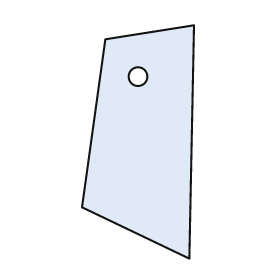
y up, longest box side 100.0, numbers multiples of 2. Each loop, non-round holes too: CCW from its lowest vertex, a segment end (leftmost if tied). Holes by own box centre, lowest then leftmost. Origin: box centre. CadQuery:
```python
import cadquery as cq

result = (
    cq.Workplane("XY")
    .moveTo(22.0, -50.0)
    .lineTo(24.0, 50.0)
    .lineTo(-14.0, 44.0)
    .lineTo(-24.0, -28.0)
    .close()
    .moveTo(0.0, 28.0)
    .circle(4.0)
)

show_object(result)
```